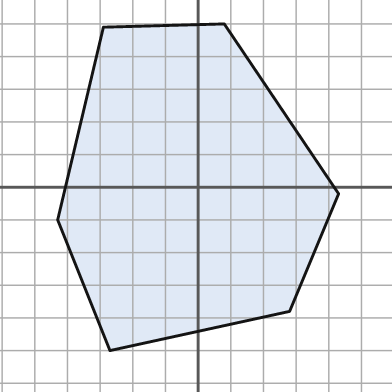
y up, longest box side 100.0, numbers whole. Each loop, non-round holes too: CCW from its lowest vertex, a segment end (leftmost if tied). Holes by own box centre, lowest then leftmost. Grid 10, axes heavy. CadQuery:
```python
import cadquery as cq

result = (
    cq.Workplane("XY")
    .moveTo(-27.0, -50.0)
    .lineTo(28.0, -38.0)
    .lineTo(43.0, -2.0)
    .lineTo(8.0, 50.0)
    .lineTo(-29.0, 49.0)
    .lineTo(-43.0, -10.0)
    .close()
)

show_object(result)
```